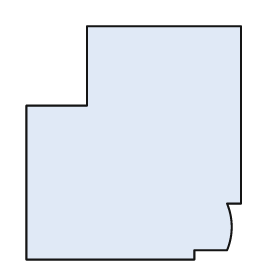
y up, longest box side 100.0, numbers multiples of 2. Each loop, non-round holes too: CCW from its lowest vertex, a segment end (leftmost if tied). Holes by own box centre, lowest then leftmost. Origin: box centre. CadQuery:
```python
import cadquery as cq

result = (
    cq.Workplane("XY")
    .moveTo(-46.0, -50.0)
    .lineTo(26.0, -50.0)
    .lineTo(26.0, -46.0)
    .lineTo(40.0, -46.0)
    .threePointArc((42.0, -36.0), (40.0, -26.0))
    .lineTo(46.0, -26.0)
    .lineTo(46.0, 50.0)
    .lineTo(-20.0, 50.0)
    .lineTo(-20.0, 16.0)
    .lineTo(-46.0, 16.0)
    .close()
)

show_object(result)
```